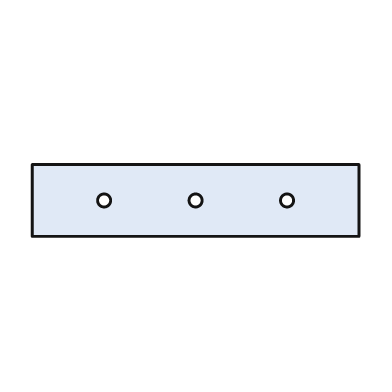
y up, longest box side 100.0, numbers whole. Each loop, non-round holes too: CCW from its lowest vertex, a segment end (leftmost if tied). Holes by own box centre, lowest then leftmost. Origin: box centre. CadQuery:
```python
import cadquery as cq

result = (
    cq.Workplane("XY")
    .moveTo(-50.0, -11.0)
    .lineTo(50.0, -11.0)
    .lineTo(50.0, 11.0)
    .lineTo(-50.0, 11.0)
    .close()
    .moveTo(-28.0, 0.0)
    .circle(2.0)
    .moveTo(0.0, 0.0)
    .circle(2.0)
    .moveTo(28.0, 0.0)
    .circle(2.0)
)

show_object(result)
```